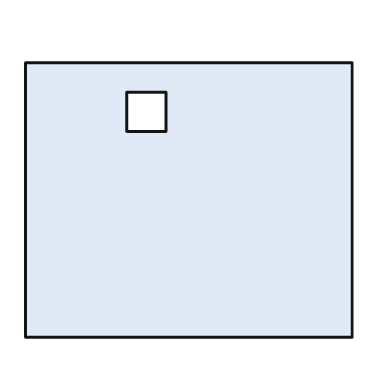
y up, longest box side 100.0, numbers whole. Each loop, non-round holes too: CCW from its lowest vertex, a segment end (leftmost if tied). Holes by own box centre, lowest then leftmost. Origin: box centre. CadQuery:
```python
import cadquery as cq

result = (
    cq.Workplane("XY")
    .moveTo(-50.0, -42.0)
    .lineTo(50.0, -42.0)
    .lineTo(50.0, 42.0)
    .lineTo(-50.0, 42.0)
    .close()
    .moveTo(-19.0, 21.0)
    .lineTo(-7.0, 21.0)
    .lineTo(-7.0, 33.0)
    .lineTo(-19.0, 33.0)
    .close()
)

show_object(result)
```